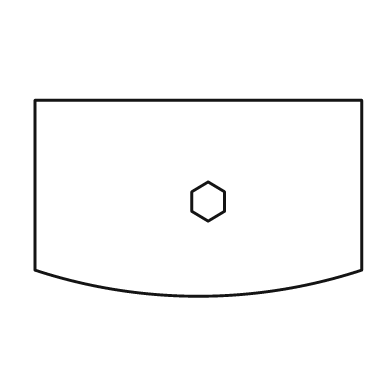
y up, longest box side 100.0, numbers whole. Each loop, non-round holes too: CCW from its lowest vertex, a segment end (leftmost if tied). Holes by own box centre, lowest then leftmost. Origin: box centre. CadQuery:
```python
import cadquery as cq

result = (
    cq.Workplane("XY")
    .moveTo(-50.0, -22.0)
    .threePointArc((0.0, -30.0), (50.0, -22.0))
    .lineTo(50.0, 30.0)
    .lineTo(-50.0, 30.0)
    .close()
    .moveTo(3.0, -7.0)
    .lineTo(8.0, -4.0)
    .lineTo(8.0, 2.0)
    .lineTo(3.0, 5.0)
    .lineTo(-2.0, 2.0)
    .lineTo(-2.0, -4.0)
    .close()
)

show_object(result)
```